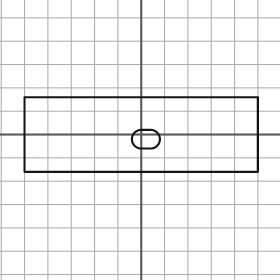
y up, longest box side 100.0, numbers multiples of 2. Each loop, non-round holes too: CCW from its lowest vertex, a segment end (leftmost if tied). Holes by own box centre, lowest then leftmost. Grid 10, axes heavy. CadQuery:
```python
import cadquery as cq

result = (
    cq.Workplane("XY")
    .moveTo(-50.0, -16.0)
    .lineTo(50.0, -16.0)
    .lineTo(50.0, 16.0)
    .lineTo(-50.0, 16.0)
    .close()
    .moveTo(0.0, -6.0)
    .lineTo(4.0, -6.0)
    .threePointArc((8.0, -2.0), (4.0, 2.0))
    .lineTo(0.0, 2.0)
    .threePointArc((-4.0, -2.0), (0.0, -6.0))
    .close()
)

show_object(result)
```